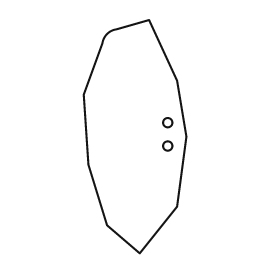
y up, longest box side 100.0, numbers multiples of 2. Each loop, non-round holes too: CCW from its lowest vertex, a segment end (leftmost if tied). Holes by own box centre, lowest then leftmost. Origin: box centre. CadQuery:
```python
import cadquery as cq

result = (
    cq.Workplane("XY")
    .moveTo(2.0, -50.0)
    .lineTo(18.0, -30.0)
    .lineTo(22.0, 0.0)
    .lineTo(18.0, 24.0)
    .lineTo(6.0, 50.0)
    .lineTo(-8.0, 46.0)
    .threePointArc((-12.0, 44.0), (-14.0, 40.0))
    .lineTo(-22.0, 18.0)
    .lineTo(-20.0, -12.0)
    .lineTo(-12.0, -38.0)
    .close()
    .moveTo(14.0, -4.0)
    .circle(2.0)
    .moveTo(14.0, 6.0)
    .circle(2.0)
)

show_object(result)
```